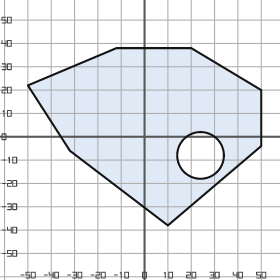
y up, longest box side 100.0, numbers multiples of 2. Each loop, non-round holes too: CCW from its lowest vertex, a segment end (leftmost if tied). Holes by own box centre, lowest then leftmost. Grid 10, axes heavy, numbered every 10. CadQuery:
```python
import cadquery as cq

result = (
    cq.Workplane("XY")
    .moveTo(10.0, -38.0)
    .lineTo(50.0, -4.0)
    .lineTo(50.0, 20.0)
    .lineTo(20.0, 38.0)
    .lineTo(-12.0, 38.0)
    .lineTo(-50.0, 22.0)
    .lineTo(-32.0, -6.0)
    .close()
    .moveTo(24.0, -8.0)
    .circle(10.0)
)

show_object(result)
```